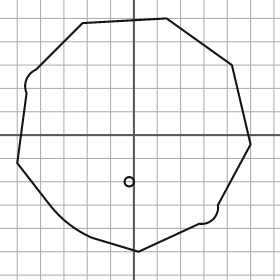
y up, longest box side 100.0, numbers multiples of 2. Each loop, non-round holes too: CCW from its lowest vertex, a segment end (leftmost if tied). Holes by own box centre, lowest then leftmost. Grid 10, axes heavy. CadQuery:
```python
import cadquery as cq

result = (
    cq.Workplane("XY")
    .moveTo(2.0, -50.0)
    .lineTo(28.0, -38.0)
    .threePointArc((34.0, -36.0), (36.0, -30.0))
    .lineTo(50.0, -4.0)
    .lineTo(42.0, 30.0)
    .lineTo(14.0, 50.0)
    .lineTo(-22.0, 48.0)
    .lineTo(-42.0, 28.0)
    .threePointArc((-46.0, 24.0), (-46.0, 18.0))
    .lineTo(-50.0, -12.0)
    .lineTo(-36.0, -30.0)
    .threePointArc((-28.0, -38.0), (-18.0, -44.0))
    .close()
    .moveTo(-2.0, -20.0)
    .circle(2.0)
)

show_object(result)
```